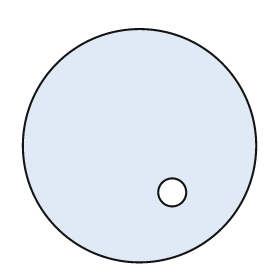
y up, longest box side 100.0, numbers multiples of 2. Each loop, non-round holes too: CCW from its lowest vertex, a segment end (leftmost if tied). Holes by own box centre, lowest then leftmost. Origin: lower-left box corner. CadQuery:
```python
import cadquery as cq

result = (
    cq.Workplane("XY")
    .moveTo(50.0, 50.0)
    .circle(50.0)
    .moveTo(64.0, 30.0)
    .circle(6.0)
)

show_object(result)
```